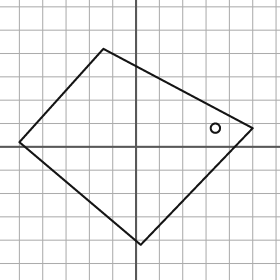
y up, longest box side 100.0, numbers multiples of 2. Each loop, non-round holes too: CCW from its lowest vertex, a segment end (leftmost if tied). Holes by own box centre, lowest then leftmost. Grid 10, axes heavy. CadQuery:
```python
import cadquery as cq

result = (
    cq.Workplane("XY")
    .moveTo(2.0, -42.0)
    .lineTo(50.0, 8.0)
    .lineTo(-14.0, 42.0)
    .lineTo(-50.0, 2.0)
    .close()
    .moveTo(34.0, 8.0)
    .circle(2.0)
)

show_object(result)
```